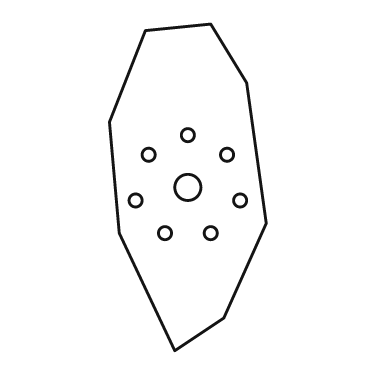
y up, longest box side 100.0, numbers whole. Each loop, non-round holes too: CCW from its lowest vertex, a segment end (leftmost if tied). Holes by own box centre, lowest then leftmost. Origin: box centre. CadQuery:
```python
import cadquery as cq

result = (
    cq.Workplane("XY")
    .moveTo(-4.0, -50.0)
    .lineTo(11.0, -40.0)
    .lineTo(24.0, -11.0)
    .lineTo(18.0, 32.0)
    .lineTo(7.0, 50.0)
    .lineTo(-13.0, 48.0)
    .lineTo(-24.0, 20.0)
    .lineTo(-21.0, -14.0)
    .close()
    .moveTo(-7.0, -14.0)
    .circle(2.0)
    .moveTo(7.0, -14.0)
    .circle(2.0)
    .moveTo(-16.0, -4.0)
    .circle(2.0)
    .moveTo(16.0, -4.0)
    .circle(2.0)
    .moveTo(0.0, 0.0)
    .circle(4.0)
    .moveTo(-12.0, 10.0)
    .circle(2.0)
    .moveTo(12.0, 10.0)
    .circle(2.0)
    .moveTo(0.0, 16.0)
    .circle(2.0)
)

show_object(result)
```